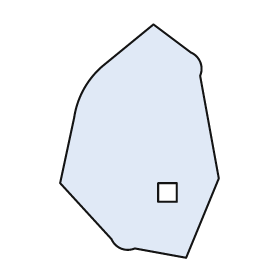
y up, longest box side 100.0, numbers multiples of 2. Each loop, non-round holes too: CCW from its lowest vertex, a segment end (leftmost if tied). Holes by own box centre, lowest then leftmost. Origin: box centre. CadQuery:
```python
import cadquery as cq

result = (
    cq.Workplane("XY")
    .moveTo(20.0, -50.0)
    .lineTo(34.0, -16.0)
    .lineTo(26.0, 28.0)
    .threePointArc((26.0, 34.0), (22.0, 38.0))
    .lineTo(6.0, 50.0)
    .lineTo(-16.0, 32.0)
    .threePointArc((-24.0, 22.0), (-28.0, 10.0))
    .lineTo(-34.0, -18.0)
    .lineTo(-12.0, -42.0)
    .threePointArc((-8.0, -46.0), (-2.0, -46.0))
    .close()
    .moveTo(8.0, -26.0)
    .lineTo(16.0, -26.0)
    .lineTo(16.0, -18.0)
    .lineTo(8.0, -18.0)
    .close()
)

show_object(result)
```